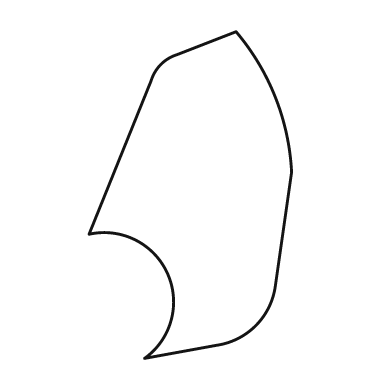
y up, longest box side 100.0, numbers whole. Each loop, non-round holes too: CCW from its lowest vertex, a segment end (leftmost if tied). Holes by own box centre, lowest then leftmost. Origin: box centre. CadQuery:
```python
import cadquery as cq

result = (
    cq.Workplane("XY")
    .moveTo(-14.0, -50.0)
    .lineTo(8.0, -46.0)
    .threePointArc((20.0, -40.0), (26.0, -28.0))
    .lineTo(31.0, 7.0)
    .threePointArc((26.0, 30.0), (14.0, 50.0))
    .lineTo(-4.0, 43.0)
    .threePointArc((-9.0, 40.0), (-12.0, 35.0))
    .lineTo(-31.0, -12.0)
    .threePointArc((-7.0, -24.0), (-14.0, -50.0))
    .close()
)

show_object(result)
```